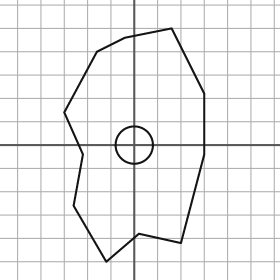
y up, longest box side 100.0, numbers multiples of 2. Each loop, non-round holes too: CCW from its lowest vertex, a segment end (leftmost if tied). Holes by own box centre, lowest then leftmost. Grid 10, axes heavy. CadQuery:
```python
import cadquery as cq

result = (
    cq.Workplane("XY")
    .moveTo(-12.0, -50.0)
    .lineTo(2.0, -38.0)
    .lineTo(20.0, -42.0)
    .lineTo(30.0, -4.0)
    .lineTo(30.0, 22.0)
    .lineTo(16.0, 50.0)
    .lineTo(-4.0, 46.0)
    .lineTo(-16.0, 40.0)
    .lineTo(-30.0, 14.0)
    .lineTo(-22.0, -4.0)
    .lineTo(-26.0, -26.0)
    .close()
    .moveTo(0.0, 0.0)
    .circle(8.0)
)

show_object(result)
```